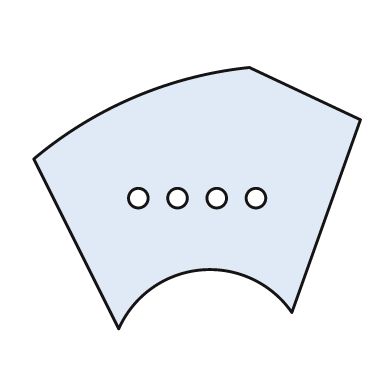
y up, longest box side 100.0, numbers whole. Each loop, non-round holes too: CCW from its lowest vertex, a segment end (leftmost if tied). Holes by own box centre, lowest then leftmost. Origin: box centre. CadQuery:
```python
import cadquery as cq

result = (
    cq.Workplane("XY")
    .moveTo(-24.0, -40.0)
    .threePointArc((1.0, -22.0), (29.0, -35.0))
    .lineTo(50.0, 24.0)
    .lineTo(16.0, 40.0)
    .threePointArc((-19.0, 31.0), (-50.0, 12.0))
    .close()
    .moveTo(-18.0, 0.0)
    .circle(3.0)
    .moveTo(-6.0, 0.0)
    .circle(3.0)
    .moveTo(6.0, 0.0)
    .circle(3.0)
    .moveTo(18.0, 0.0)
    .circle(3.0)
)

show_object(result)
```